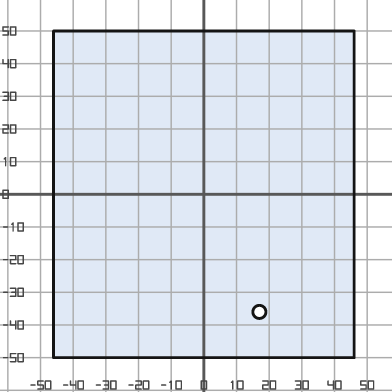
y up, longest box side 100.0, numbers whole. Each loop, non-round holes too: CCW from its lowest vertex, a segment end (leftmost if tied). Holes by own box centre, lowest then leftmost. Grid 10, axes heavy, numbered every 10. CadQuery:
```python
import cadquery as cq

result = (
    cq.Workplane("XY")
    .moveTo(-46.0, -50.0)
    .lineTo(46.0, -50.0)
    .lineTo(46.0, 50.0)
    .lineTo(-46.0, 50.0)
    .close()
    .moveTo(17.0, -36.0)
    .circle(2.0)
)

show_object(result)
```